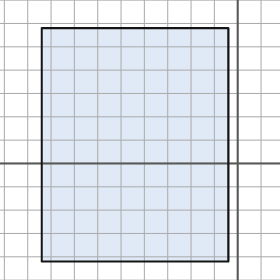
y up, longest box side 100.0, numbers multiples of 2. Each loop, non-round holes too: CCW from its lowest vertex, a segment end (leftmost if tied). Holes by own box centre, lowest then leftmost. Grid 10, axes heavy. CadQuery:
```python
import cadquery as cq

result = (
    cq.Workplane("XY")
    .moveTo(-84.0, -42.0)
    .lineTo(-4.0, -42.0)
    .lineTo(-4.0, 58.0)
    .lineTo(-84.0, 58.0)
    .close()
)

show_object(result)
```